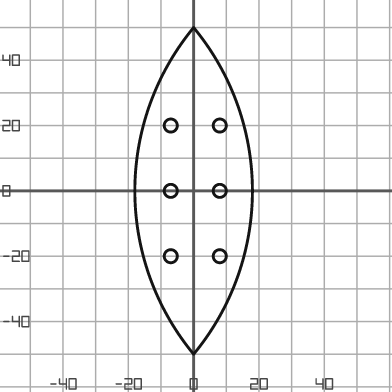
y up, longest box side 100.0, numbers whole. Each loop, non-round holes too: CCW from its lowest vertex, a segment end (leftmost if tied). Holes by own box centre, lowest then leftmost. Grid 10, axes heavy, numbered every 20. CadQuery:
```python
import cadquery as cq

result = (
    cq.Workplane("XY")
    .moveTo(0.0, -50.0)
    .threePointArc((18.0, 0.0), (0.0, 50.0))
    .threePointArc((-18.0, 0.0), (0.0, -50.0))
    .close()
    .moveTo(-7.0, -20.0)
    .circle(2.0)
    .moveTo(8.0, -20.0)
    .circle(2.0)
    .moveTo(-7.0, 0.0)
    .circle(2.0)
    .moveTo(8.0, 0.0)
    .circle(2.0)
    .moveTo(-7.0, 20.0)
    .circle(2.0)
    .moveTo(8.0, 20.0)
    .circle(2.0)
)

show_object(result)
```